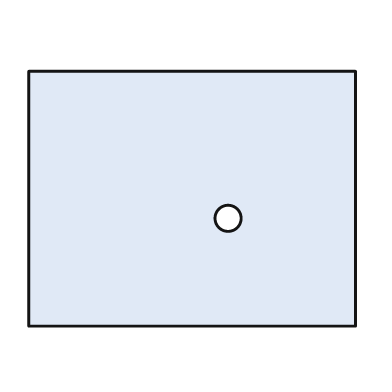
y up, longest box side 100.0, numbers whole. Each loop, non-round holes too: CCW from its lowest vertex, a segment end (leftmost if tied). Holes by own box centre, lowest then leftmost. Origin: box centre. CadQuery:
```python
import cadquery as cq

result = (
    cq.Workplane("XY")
    .moveTo(-50.0, -39.0)
    .lineTo(50.0, -39.0)
    .lineTo(50.0, 39.0)
    .lineTo(-50.0, 39.0)
    .close()
    .moveTo(11.0, -6.0)
    .circle(4.0)
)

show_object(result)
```